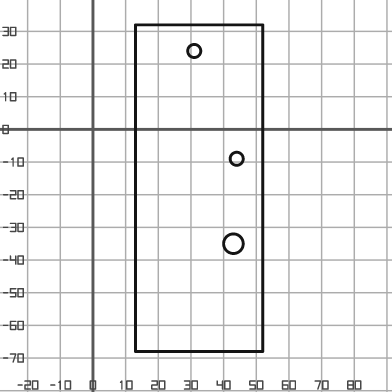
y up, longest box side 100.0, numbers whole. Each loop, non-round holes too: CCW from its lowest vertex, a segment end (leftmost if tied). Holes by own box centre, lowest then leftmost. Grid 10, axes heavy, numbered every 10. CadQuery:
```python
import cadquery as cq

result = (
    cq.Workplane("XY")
    .moveTo(13.0, -68.0)
    .lineTo(52.0, -68.0)
    .lineTo(52.0, 32.0)
    .lineTo(13.0, 32.0)
    .close()
    .moveTo(43.0, -35.0)
    .circle(3.0)
    .moveTo(44.0, -9.0)
    .circle(2.0)
    .moveTo(31.0, 24.0)
    .circle(2.0)
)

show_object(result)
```